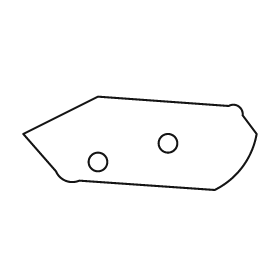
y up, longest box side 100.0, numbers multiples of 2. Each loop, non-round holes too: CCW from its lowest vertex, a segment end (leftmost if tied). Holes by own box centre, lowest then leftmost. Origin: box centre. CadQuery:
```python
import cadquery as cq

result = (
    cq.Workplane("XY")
    .moveTo(32.0, -20.0)
    .threePointArc((44.0, -10.0), (50.0, 4.0))
    .lineTo(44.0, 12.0)
    .threePointArc((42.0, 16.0), (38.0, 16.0))
    .lineTo(-18.0, 20.0)
    .lineTo(-50.0, 4.0)
    .lineTo(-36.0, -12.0)
    .threePointArc((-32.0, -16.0), (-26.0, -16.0))
    .close()
    .moveTo(-18.0, -8.0)
    .circle(4.0)
    .moveTo(12.0, 0.0)
    .circle(4.0)
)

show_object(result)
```